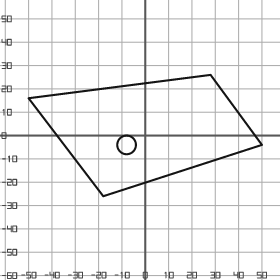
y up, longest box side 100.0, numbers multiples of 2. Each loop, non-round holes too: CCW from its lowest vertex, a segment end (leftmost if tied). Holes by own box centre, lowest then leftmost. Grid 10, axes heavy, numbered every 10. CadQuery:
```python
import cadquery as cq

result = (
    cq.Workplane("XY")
    .moveTo(-18.0, -26.0)
    .lineTo(50.0, -4.0)
    .lineTo(28.0, 26.0)
    .lineTo(-50.0, 16.0)
    .close()
    .moveTo(-8.0, -4.0)
    .circle(4.0)
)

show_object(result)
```